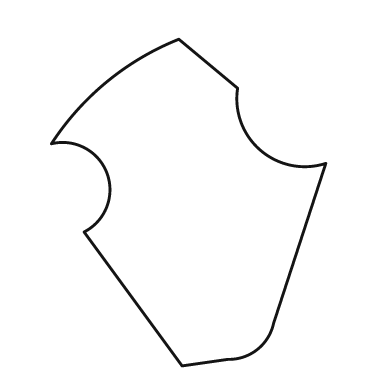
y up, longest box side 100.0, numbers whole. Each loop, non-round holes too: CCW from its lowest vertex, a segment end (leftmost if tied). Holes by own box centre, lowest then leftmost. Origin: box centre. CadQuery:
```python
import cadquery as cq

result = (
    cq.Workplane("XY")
    .moveTo(-2.0, -50.0)
    .lineTo(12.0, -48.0)
    .threePointArc((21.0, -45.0), (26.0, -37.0))
    .lineTo(42.0, 12.0)
    .threePointArc((22.0, 16.0), (15.0, 35.0))
    .lineTo(-3.0, 50.0)
    .threePointArc((-25.0, 37.0), (-42.0, 18.0))
    .threePointArc((-25.0, 9.0), (-32.0, -9.0))
    .close()
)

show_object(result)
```